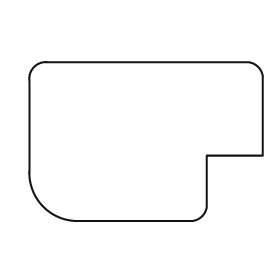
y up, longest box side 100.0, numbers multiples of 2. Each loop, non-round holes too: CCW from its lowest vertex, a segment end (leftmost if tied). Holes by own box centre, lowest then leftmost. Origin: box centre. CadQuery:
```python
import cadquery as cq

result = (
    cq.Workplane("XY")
    .moveTo(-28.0, -34.0)
    .lineTo(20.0, -34.0)
    .threePointArc((24.0, -32.0), (26.0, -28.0))
    .lineTo(26.0, -6.0)
    .lineTo(50.0, -6.0)
    .lineTo(50.0, 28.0)
    .threePointArc((48.0, 32.0), (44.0, 34.0))
    .lineTo(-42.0, 34.0)
    .threePointArc((-48.0, 32.0), (-50.0, 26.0))
    .lineTo(-50.0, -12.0)
    .threePointArc((-44.0, -28.0), (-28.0, -34.0))
    .close()
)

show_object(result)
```